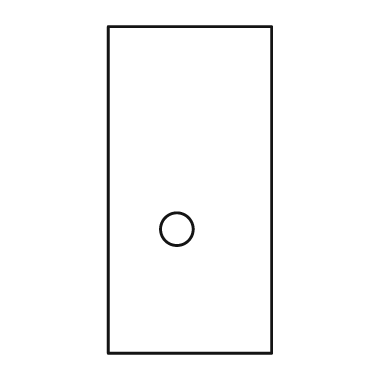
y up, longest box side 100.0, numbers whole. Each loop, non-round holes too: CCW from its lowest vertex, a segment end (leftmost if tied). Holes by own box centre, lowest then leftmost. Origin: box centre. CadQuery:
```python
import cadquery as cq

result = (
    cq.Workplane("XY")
    .moveTo(-25.0, -50.0)
    .lineTo(25.0, -50.0)
    .lineTo(25.0, 50.0)
    .lineTo(-25.0, 50.0)
    .close()
    .moveTo(-4.0, -12.0)
    .circle(5.0)
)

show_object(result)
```